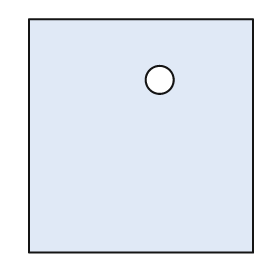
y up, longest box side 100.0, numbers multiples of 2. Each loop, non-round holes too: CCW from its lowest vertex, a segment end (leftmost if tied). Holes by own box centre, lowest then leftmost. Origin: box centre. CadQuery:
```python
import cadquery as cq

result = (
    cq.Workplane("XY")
    .moveTo(-48.0, -50.0)
    .lineTo(48.0, -50.0)
    .lineTo(48.0, 50.0)
    .lineTo(-48.0, 50.0)
    .close()
    .moveTo(8.0, 24.0)
    .circle(6.0)
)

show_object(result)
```